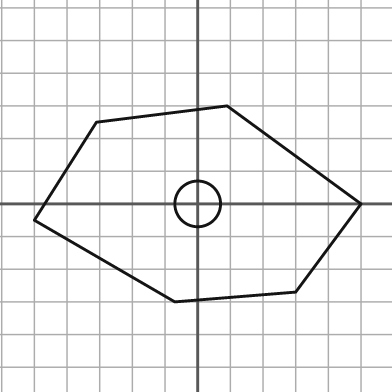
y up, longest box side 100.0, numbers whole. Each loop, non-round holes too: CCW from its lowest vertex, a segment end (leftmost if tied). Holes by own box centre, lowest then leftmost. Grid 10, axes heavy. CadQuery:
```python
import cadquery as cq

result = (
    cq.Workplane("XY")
    .moveTo(-7.0, -30.0)
    .lineTo(30.0, -27.0)
    .lineTo(50.0, 0.0)
    .lineTo(9.0, 30.0)
    .lineTo(-31.0, 25.0)
    .lineTo(-50.0, -5.0)
    .close()
    .moveTo(0.0, 0.0)
    .circle(7.0)
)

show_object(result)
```